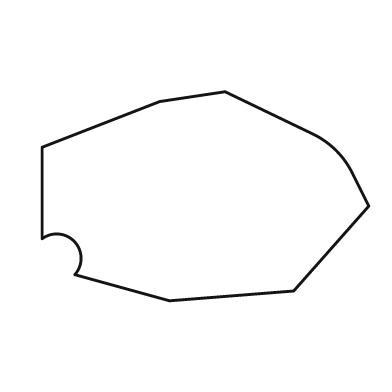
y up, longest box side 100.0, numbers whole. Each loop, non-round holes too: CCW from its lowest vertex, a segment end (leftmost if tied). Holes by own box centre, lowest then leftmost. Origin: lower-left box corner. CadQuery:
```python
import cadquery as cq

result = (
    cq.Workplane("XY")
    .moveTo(39.0, 0.0)
    .lineTo(77.0, 3.0)
    .lineTo(100.0, 29.0)
    .lineTo(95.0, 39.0)
    .threePointArc((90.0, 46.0), (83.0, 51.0))
    .lineTo(56.0, 64.0)
    .lineTo(36.0, 61.0)
    .lineTo(0.0, 47.0)
    .lineTo(0.0, 19.0)
    .threePointArc((10.0, 18.0), (10.0, 8.0))
    .close()
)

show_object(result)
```